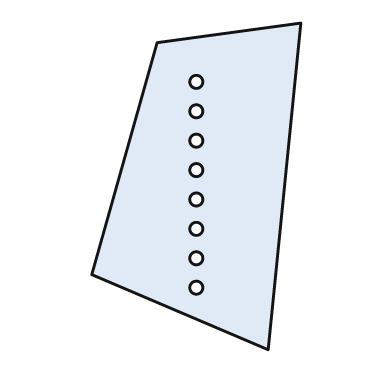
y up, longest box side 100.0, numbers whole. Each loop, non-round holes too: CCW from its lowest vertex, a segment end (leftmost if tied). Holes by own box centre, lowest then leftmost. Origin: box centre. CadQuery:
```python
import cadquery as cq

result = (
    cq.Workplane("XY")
    .moveTo(22.0, -50.0)
    .lineTo(32.0, 50.0)
    .lineTo(-12.0, 44.0)
    .lineTo(-32.0, -27.0)
    .close()
    .moveTo(0.0, -31.0)
    .circle(2.0)
    .moveTo(0.0, -22.0)
    .circle(2.0)
    .moveTo(0.0, -13.0)
    .circle(2.0)
    .moveTo(0.0, -4.0)
    .circle(2.0)
    .moveTo(0.0, 5.0)
    .circle(2.0)
    .moveTo(0.0, 14.0)
    .circle(2.0)
    .moveTo(0.0, 23.0)
    .circle(2.0)
    .moveTo(0.0, 32.0)
    .circle(2.0)
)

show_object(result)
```